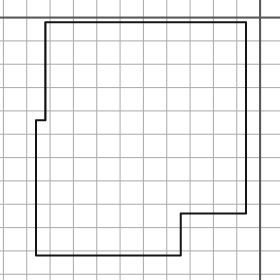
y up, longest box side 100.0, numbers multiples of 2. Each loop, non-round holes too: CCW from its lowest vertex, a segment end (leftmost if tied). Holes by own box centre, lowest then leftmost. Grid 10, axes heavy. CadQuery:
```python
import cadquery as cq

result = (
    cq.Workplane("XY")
    .moveTo(-96.0, -102.0)
    .lineTo(-34.0, -102.0)
    .lineTo(-34.0, -84.0)
    .lineTo(-6.0, -84.0)
    .lineTo(-6.0, -2.0)
    .lineTo(-92.0, -2.0)
    .lineTo(-92.0, -44.0)
    .lineTo(-96.0, -44.0)
    .close()
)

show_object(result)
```